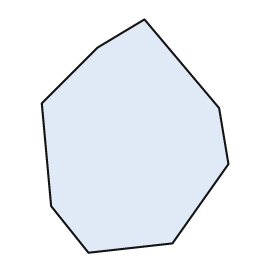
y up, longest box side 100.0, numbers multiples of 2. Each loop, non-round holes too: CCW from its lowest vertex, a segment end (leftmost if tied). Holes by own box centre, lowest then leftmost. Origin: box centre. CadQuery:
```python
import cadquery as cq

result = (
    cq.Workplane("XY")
    .moveTo(-20.0, -50.0)
    .lineTo(16.0, -46.0)
    .lineTo(40.0, -12.0)
    .lineTo(36.0, 12.0)
    .lineTo(4.0, 50.0)
    .lineTo(-16.0, 38.0)
    .lineTo(-40.0, 14.0)
    .lineTo(-36.0, -30.0)
    .close()
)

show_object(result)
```